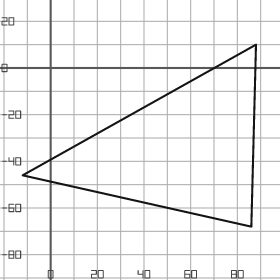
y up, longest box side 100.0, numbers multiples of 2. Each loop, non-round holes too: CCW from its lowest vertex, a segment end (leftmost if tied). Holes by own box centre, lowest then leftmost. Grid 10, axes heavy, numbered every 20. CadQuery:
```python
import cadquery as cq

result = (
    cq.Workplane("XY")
    .moveTo(86.0, -68.0)
    .lineTo(88.0, 10.0)
    .lineTo(-12.0, -46.0)
    .close()
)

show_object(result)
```